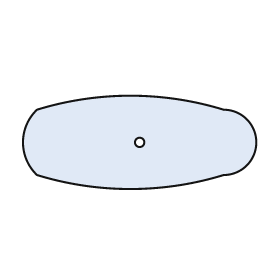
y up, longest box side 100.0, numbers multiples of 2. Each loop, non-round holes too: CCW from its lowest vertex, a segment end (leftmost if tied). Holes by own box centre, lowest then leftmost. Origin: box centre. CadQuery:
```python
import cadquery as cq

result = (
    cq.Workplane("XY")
    .moveTo(-44.0, -14.0)
    .threePointArc((-4.0, -20.0), (36.0, -14.0))
    .threePointArc((50.0, 0.0), (36.0, 14.0))
    .threePointArc((-4.0, 20.0), (-44.0, 14.0))
    .threePointArc((-50.0, 0.0), (-44.0, -14.0))
    .close()
    .moveTo(0.0, 0.0)
    .circle(2.0)
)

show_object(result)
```